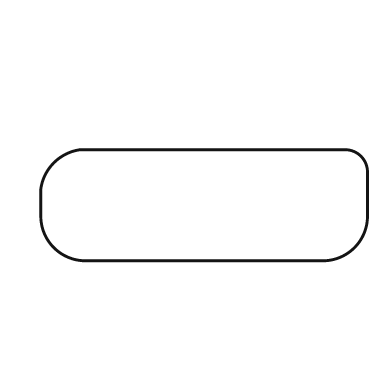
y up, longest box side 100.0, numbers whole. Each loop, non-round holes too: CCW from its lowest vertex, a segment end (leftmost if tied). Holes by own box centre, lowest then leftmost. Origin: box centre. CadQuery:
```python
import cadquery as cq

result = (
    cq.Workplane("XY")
    .moveTo(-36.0, -17.0)
    .lineTo(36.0, -17.0)
    .threePointArc((46.0, -13.0), (50.0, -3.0))
    .lineTo(50.0, 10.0)
    .threePointArc((48.0, 15.0), (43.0, 17.0))
    .lineTo(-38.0, 17.0)
    .threePointArc((-46.0, 13.0), (-50.0, 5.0))
    .lineTo(-50.0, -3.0)
    .threePointArc((-46.0, -13.0), (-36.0, -17.0))
    .close()
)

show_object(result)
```